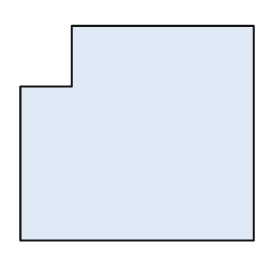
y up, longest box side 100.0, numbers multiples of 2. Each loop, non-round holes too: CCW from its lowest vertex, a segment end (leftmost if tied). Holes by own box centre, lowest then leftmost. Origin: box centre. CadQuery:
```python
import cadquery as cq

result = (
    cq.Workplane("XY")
    .moveTo(-50.0, -46.0)
    .lineTo(50.0, -46.0)
    .lineTo(50.0, 46.0)
    .lineTo(-28.0, 46.0)
    .lineTo(-28.0, 20.0)
    .lineTo(-50.0, 20.0)
    .close()
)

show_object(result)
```